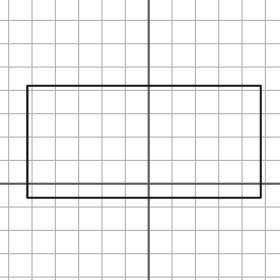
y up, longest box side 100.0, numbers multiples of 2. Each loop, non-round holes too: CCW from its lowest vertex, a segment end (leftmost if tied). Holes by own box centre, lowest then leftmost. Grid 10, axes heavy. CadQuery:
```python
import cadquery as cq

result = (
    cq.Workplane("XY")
    .moveTo(-52.0, -6.0)
    .lineTo(48.0, -6.0)
    .lineTo(48.0, 42.0)
    .lineTo(-52.0, 42.0)
    .close()
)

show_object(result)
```